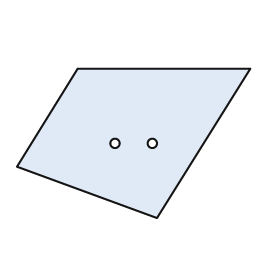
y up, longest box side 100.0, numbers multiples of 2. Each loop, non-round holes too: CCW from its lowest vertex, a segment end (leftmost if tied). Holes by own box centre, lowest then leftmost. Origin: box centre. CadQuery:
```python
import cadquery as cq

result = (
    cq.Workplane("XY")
    .moveTo(10.0, -32.0)
    .lineTo(50.0, 32.0)
    .lineTo(-24.0, 32.0)
    .lineTo(-50.0, -10.0)
    .close()
    .moveTo(-8.0, 0.0)
    .circle(2.0)
    .moveTo(8.0, 0.0)
    .circle(2.0)
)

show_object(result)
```